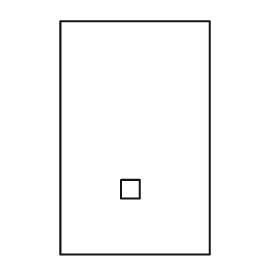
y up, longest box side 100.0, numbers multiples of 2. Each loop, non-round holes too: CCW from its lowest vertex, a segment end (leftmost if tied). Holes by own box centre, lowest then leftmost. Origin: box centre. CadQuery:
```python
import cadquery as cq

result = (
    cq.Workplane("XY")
    .moveTo(-32.0, -50.0)
    .lineTo(32.0, -50.0)
    .lineTo(32.0, 50.0)
    .lineTo(-32.0, 50.0)
    .close()
    .moveTo(-6.0, -26.0)
    .lineTo(2.0, -26.0)
    .lineTo(2.0, -18.0)
    .lineTo(-6.0, -18.0)
    .close()
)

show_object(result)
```